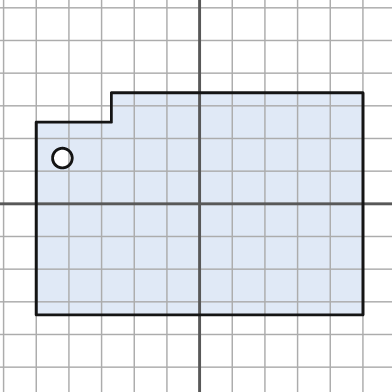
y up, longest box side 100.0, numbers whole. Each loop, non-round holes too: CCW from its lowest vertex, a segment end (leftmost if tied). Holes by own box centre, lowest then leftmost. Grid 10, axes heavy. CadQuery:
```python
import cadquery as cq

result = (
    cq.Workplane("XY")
    .moveTo(-50.0, -34.0)
    .lineTo(50.0, -34.0)
    .lineTo(50.0, 34.0)
    .lineTo(-27.0, 34.0)
    .lineTo(-27.0, 25.0)
    .lineTo(-50.0, 25.0)
    .close()
    .moveTo(-42.0, 14.0)
    .circle(3.0)
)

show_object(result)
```